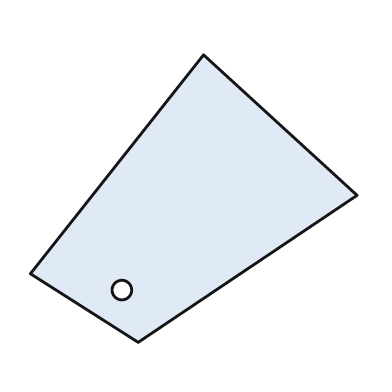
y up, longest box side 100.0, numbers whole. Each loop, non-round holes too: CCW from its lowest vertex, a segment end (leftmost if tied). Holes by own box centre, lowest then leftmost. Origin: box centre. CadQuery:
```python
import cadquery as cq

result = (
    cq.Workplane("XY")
    .moveTo(-17.0, -44.0)
    .lineTo(50.0, 1.0)
    .lineTo(3.0, 44.0)
    .lineTo(-50.0, -23.0)
    .close()
    .moveTo(-22.0, -28.0)
    .circle(3.0)
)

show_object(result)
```